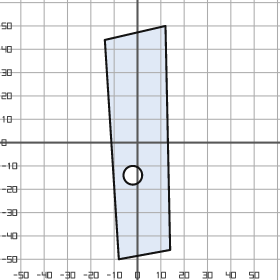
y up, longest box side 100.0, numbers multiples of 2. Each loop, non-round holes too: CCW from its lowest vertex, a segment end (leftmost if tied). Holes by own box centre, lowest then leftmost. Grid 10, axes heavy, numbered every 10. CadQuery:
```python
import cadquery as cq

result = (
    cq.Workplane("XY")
    .moveTo(-8.0, -50.0)
    .lineTo(14.0, -46.0)
    .lineTo(12.0, 50.0)
    .lineTo(-14.0, 44.0)
    .close()
    .moveTo(-2.0, -14.0)
    .circle(4.0)
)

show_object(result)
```